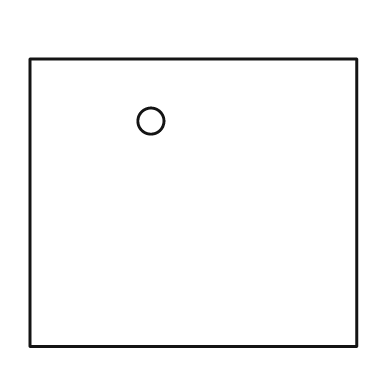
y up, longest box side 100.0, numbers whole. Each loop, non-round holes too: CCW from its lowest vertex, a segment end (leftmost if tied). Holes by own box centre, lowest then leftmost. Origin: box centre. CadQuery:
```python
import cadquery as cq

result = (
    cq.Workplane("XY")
    .moveTo(-50.0, -44.0)
    .lineTo(50.0, -44.0)
    .lineTo(50.0, 44.0)
    .lineTo(-50.0, 44.0)
    .close()
    .moveTo(-13.0, 25.0)
    .circle(4.0)
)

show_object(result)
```